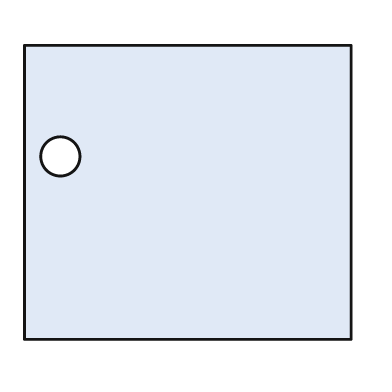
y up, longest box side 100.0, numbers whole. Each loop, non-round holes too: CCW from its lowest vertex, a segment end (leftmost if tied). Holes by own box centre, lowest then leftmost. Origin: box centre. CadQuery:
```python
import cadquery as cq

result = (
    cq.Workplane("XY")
    .moveTo(-50.0, -45.0)
    .lineTo(50.0, -45.0)
    .lineTo(50.0, 45.0)
    .lineTo(-50.0, 45.0)
    .close()
    .moveTo(-39.0, 11.0)
    .circle(6.0)
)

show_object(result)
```